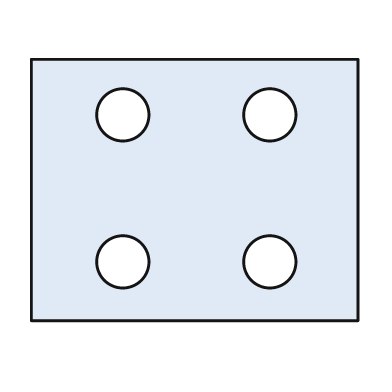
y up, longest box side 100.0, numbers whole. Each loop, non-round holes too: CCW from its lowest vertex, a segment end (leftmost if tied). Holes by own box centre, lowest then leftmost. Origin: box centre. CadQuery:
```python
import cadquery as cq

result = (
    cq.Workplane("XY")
    .moveTo(-50.0, -40.0)
    .lineTo(50.0, -40.0)
    .lineTo(50.0, 40.0)
    .lineTo(-50.0, 40.0)
    .close()
    .moveTo(-22.0, -22.0)
    .circle(8.0)
    .moveTo(23.0, -22.0)
    .circle(8.0)
    .moveTo(-22.0, 23.0)
    .circle(8.0)
    .moveTo(23.0, 23.0)
    .circle(8.0)
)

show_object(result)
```